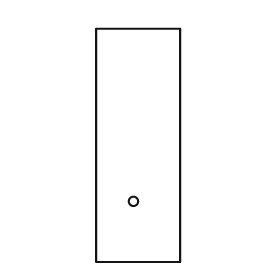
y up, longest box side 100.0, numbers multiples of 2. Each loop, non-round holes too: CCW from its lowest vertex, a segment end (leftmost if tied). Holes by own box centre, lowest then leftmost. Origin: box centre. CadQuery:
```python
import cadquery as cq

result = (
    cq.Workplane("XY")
    .moveTo(-18.0, -50.0)
    .lineTo(18.0, -50.0)
    .lineTo(18.0, 50.0)
    .lineTo(-18.0, 50.0)
    .close()
    .moveTo(-2.0, -24.0)
    .circle(2.0)
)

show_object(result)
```